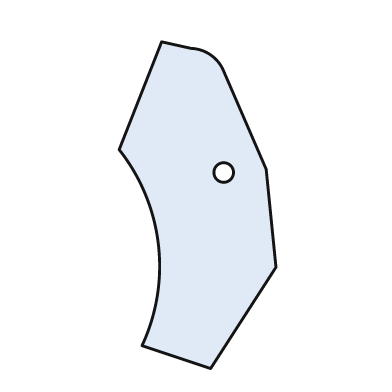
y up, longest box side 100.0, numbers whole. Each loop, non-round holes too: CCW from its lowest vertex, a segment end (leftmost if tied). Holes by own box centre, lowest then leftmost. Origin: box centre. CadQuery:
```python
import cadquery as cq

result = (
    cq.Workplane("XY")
    .moveTo(4.0, -50.0)
    .lineTo(24.0, -19.0)
    .lineTo(21.0, 11.0)
    .lineTo(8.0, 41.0)
    .threePointArc((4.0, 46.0), (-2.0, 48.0))
    .lineTo(-11.0, 50.0)
    .lineTo(-24.0, 17.0)
    .threePointArc((-12.0, -12.0), (-17.0, -43.0))
    .close()
    .moveTo(8.0, 10.0)
    .circle(3.0)
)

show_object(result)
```